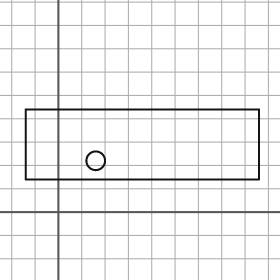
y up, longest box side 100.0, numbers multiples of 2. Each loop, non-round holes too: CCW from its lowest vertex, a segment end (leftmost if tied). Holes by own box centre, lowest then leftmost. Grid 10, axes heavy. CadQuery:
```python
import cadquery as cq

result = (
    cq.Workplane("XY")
    .moveTo(-14.0, 14.0)
    .lineTo(86.0, 14.0)
    .lineTo(86.0, 44.0)
    .lineTo(-14.0, 44.0)
    .close()
    .moveTo(16.0, 22.0)
    .circle(4.0)
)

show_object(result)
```